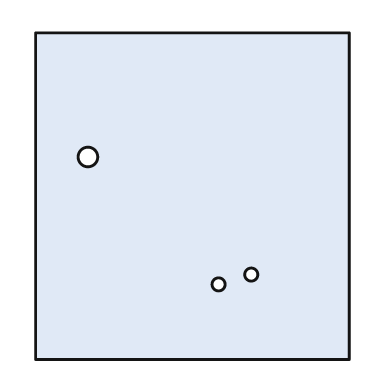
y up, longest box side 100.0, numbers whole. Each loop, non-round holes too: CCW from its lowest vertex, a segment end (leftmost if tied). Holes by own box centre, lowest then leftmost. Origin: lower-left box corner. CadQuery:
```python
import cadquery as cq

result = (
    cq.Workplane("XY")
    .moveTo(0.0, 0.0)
    .lineTo(96.0, 0.0)
    .lineTo(96.0, 100.0)
    .lineTo(0.0, 100.0)
    .close()
    .moveTo(56.0, 23.0)
    .circle(2.0)
    .moveTo(66.0, 26.0)
    .circle(2.0)
    .moveTo(16.0, 62.0)
    .circle(3.0)
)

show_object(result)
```